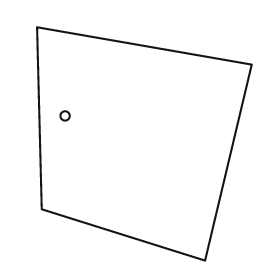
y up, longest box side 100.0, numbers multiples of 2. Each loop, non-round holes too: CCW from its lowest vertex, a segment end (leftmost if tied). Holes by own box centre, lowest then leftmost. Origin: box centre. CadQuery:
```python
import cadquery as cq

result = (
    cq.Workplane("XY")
    .moveTo(26.0, -50.0)
    .lineTo(46.0, 34.0)
    .lineTo(-46.0, 50.0)
    .lineTo(-44.0, -28.0)
    .close()
    .moveTo(-34.0, 12.0)
    .circle(2.0)
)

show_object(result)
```